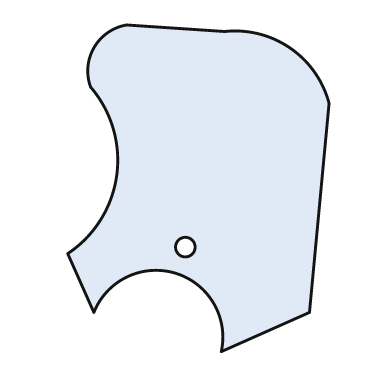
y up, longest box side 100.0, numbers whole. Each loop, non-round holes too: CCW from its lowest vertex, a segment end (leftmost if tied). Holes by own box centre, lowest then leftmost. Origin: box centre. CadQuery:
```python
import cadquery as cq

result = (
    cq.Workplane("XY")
    .moveTo(7.0, -50.0)
    .lineTo(34.0, -38.0)
    .lineTo(40.0, 26.0)
    .threePointArc((28.0, 43.0), (8.0, 48.0))
    .lineTo(-22.0, 50.0)
    .threePointArc((-32.0, 43.0), (-33.0, 31.0))
    .threePointArc((-25.0, 4.0), (-40.0, -20.0))
    .lineTo(-32.0, -38.0)
    .threePointArc((-7.0, -26.0), (7.0, -50.0))
    .close()
    .moveTo(-4.0, -18.0)
    .circle(3.0)
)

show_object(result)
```